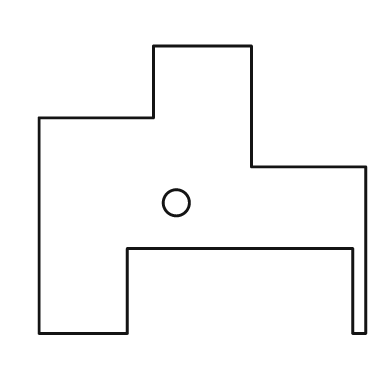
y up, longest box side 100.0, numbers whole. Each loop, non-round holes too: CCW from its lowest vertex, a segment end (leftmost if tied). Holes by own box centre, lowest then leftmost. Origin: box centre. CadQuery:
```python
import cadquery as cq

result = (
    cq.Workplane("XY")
    .moveTo(-50.0, -44.0)
    .lineTo(-23.0, -44.0)
    .lineTo(-23.0, -18.0)
    .lineTo(46.0, -18.0)
    .lineTo(46.0, -44.0)
    .lineTo(50.0, -44.0)
    .lineTo(50.0, 7.0)
    .lineTo(15.0, 7.0)
    .lineTo(15.0, 44.0)
    .lineTo(-15.0, 44.0)
    .lineTo(-15.0, 22.0)
    .lineTo(-50.0, 22.0)
    .close()
    .moveTo(-8.0, -4.0)
    .circle(4.0)
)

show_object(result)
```